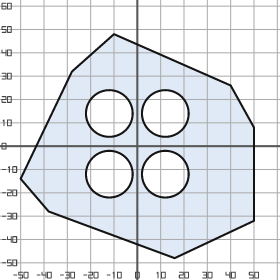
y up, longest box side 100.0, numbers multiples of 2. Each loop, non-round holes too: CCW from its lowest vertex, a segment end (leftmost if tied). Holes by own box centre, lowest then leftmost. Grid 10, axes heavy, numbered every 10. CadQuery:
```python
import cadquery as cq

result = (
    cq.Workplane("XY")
    .moveTo(16.0, -48.0)
    .lineTo(50.0, -32.0)
    .lineTo(50.0, 8.0)
    .lineTo(40.0, 26.0)
    .lineTo(-10.0, 48.0)
    .lineTo(-28.0, 32.0)
    .lineTo(-50.0, -14.0)
    .lineTo(-38.0, -28.0)
    .close()
    .moveTo(-12.0, -12.0)
    .circle(10.0)
    .moveTo(12.0, -12.0)
    .circle(10.0)
    .moveTo(-12.0, 14.0)
    .circle(10.0)
    .moveTo(12.0, 14.0)
    .circle(10.0)
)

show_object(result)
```